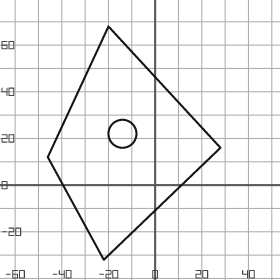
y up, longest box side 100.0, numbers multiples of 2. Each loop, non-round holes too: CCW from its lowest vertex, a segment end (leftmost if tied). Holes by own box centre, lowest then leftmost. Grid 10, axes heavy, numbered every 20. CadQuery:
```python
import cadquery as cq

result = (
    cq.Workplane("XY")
    .moveTo(-22.0, -32.0)
    .lineTo(28.0, 16.0)
    .lineTo(-20.0, 68.0)
    .lineTo(-46.0, 12.0)
    .close()
    .moveTo(-14.0, 22.0)
    .circle(6.0)
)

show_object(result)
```